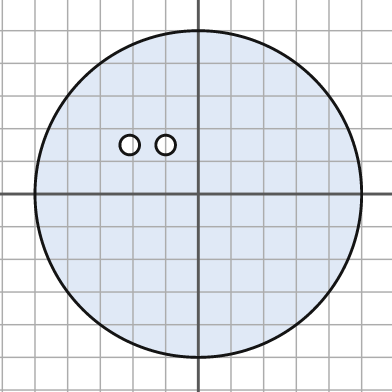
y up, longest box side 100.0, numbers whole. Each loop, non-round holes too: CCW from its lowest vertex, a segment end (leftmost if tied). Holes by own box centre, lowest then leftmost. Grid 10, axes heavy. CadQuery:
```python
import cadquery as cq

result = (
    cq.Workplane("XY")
    .moveTo(0.0, 0.0)
    .circle(50.0)
    .moveTo(-21.0, 15.0)
    .circle(3.0)
    .moveTo(-10.0, 15.0)
    .circle(3.0)
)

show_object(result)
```